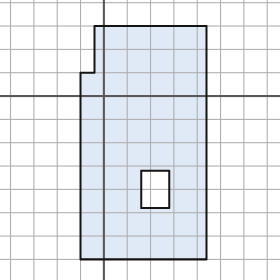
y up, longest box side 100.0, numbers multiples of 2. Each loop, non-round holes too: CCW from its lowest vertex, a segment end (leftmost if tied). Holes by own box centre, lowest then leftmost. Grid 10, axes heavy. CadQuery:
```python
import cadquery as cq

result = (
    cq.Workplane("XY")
    .moveTo(-10.0, -70.0)
    .lineTo(44.0, -70.0)
    .lineTo(44.0, 30.0)
    .lineTo(-4.0, 30.0)
    .lineTo(-4.0, 10.0)
    .lineTo(-10.0, 10.0)
    .close()
    .moveTo(16.0, -48.0)
    .lineTo(28.0, -48.0)
    .lineTo(28.0, -32.0)
    .lineTo(16.0, -32.0)
    .close()
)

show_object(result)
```